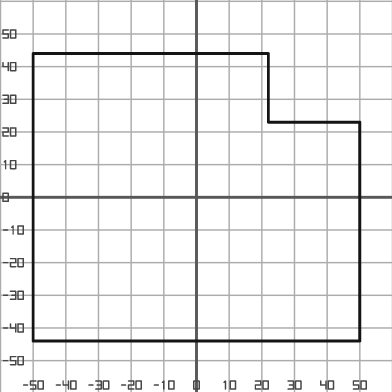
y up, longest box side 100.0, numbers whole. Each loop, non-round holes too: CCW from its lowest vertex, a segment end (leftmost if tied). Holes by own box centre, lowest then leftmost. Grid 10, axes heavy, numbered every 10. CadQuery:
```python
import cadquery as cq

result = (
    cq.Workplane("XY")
    .moveTo(-50.0, -44.0)
    .lineTo(50.0, -44.0)
    .lineTo(50.0, 23.0)
    .lineTo(22.0, 23.0)
    .lineTo(22.0, 44.0)
    .lineTo(-50.0, 44.0)
    .close()
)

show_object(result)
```